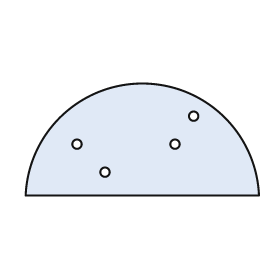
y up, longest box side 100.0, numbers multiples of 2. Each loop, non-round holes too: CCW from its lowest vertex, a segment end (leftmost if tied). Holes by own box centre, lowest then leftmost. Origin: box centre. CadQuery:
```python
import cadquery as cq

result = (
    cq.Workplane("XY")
    .moveTo(-50.0, -24.0)
    .lineTo(50.0, -24.0)
    .threePointArc((0.0, 24.0), (-50.0, -24.0))
    .close()
    .moveTo(-16.0, -14.0)
    .circle(2.0)
    .moveTo(-28.0, -2.0)
    .circle(2.0)
    .moveTo(14.0, -2.0)
    .circle(2.0)
    .moveTo(22.0, 10.0)
    .circle(2.0)
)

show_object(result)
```